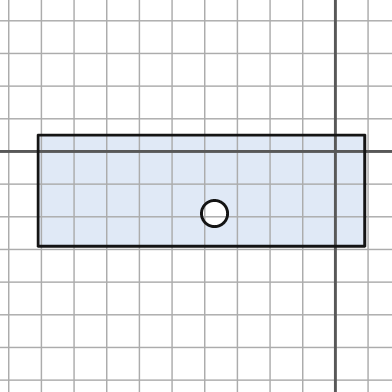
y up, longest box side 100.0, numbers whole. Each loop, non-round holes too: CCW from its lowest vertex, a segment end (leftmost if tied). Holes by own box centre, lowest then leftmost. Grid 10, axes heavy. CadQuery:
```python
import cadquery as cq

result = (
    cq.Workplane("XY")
    .moveTo(-91.0, -29.0)
    .lineTo(9.0, -29.0)
    .lineTo(9.0, 5.0)
    .lineTo(-91.0, 5.0)
    .close()
    .moveTo(-37.0, -19.0)
    .circle(4.0)
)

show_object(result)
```